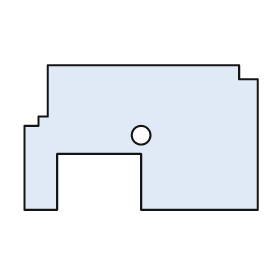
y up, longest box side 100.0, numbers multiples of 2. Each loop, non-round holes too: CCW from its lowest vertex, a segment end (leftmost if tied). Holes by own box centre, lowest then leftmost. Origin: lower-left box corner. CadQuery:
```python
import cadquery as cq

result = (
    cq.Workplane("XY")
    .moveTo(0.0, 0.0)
    .lineTo(14.0, 0.0)
    .lineTo(14.0, 24.0)
    .lineTo(50.0, 24.0)
    .lineTo(50.0, 0.0)
    .lineTo(100.0, 0.0)
    .lineTo(100.0, 56.0)
    .lineTo(92.0, 56.0)
    .lineTo(92.0, 62.0)
    .lineTo(10.0, 62.0)
    .lineTo(10.0, 40.0)
    .lineTo(6.0, 40.0)
    .lineTo(6.0, 36.0)
    .lineTo(0.0, 36.0)
    .close()
    .moveTo(50.0, 32.0)
    .circle(4.0)
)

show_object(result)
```